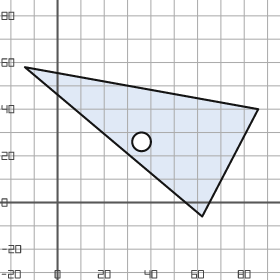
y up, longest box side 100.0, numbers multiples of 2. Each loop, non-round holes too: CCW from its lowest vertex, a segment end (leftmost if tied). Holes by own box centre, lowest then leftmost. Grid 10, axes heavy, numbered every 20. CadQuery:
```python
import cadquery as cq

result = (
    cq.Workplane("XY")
    .moveTo(62.0, -6.0)
    .lineTo(86.0, 40.0)
    .lineTo(-14.0, 58.0)
    .close()
    .moveTo(36.0, 26.0)
    .circle(4.0)
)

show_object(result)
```